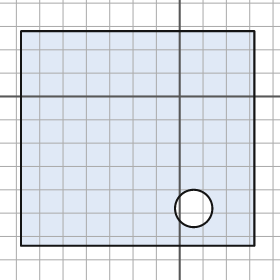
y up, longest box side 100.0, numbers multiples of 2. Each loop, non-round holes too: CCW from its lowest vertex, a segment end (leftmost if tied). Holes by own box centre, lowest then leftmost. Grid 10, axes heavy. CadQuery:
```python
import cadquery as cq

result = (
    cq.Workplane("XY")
    .moveTo(-68.0, -64.0)
    .lineTo(32.0, -64.0)
    .lineTo(32.0, 28.0)
    .lineTo(-68.0, 28.0)
    .close()
    .moveTo(6.0, -48.0)
    .circle(8.0)
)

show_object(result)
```